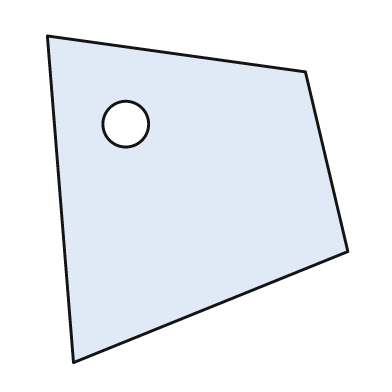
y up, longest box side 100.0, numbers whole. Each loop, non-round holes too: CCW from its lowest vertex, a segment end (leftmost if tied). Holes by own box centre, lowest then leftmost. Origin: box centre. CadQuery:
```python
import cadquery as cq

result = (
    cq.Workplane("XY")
    .moveTo(-38.0, -50.0)
    .lineTo(46.0, -16.0)
    .lineTo(33.0, 39.0)
    .lineTo(-46.0, 50.0)
    .close()
    .moveTo(-22.0, 23.0)
    .circle(7.0)
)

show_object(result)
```